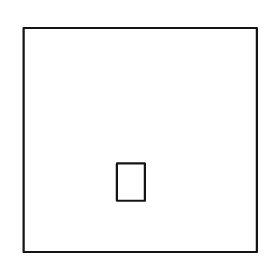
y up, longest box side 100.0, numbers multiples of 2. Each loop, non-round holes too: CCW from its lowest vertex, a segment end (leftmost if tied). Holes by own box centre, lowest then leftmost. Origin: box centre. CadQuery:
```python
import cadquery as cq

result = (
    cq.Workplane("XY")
    .moveTo(-50.0, -48.0)
    .lineTo(50.0, -48.0)
    .lineTo(50.0, 48.0)
    .lineTo(-50.0, 48.0)
    .close()
    .moveTo(-10.0, -26.0)
    .lineTo(2.0, -26.0)
    .lineTo(2.0, -10.0)
    .lineTo(-10.0, -10.0)
    .close()
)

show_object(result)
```